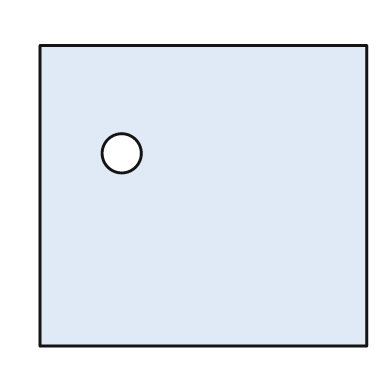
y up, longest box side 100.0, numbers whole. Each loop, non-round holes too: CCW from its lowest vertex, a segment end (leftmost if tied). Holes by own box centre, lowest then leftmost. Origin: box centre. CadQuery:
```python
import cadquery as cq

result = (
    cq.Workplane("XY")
    .moveTo(-50.0, -46.0)
    .lineTo(50.0, -46.0)
    .lineTo(50.0, 46.0)
    .lineTo(-50.0, 46.0)
    .close()
    .moveTo(-25.0, 13.0)
    .circle(6.0)
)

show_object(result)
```